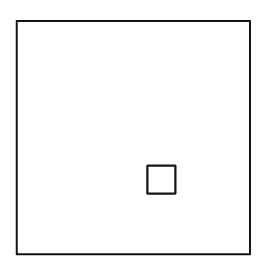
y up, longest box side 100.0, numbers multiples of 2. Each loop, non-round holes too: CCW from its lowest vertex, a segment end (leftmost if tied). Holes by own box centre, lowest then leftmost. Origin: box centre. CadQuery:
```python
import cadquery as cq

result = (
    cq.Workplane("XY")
    .moveTo(-50.0, -50.0)
    .lineTo(50.0, -50.0)
    .lineTo(50.0, 50.0)
    .lineTo(-50.0, 50.0)
    .close()
    .moveTo(6.0, -24.0)
    .lineTo(18.0, -24.0)
    .lineTo(18.0, -12.0)
    .lineTo(6.0, -12.0)
    .close()
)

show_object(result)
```